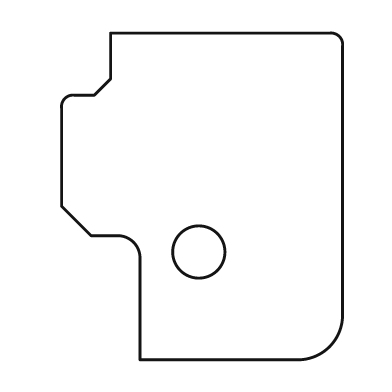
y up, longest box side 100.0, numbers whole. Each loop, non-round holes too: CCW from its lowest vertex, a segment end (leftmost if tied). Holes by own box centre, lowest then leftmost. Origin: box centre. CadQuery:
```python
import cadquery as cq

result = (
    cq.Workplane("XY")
    .moveTo(-19.0, -50.0)
    .lineTo(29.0, -50.0)
    .threePointArc((39.0, -46.0), (43.0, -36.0))
    .lineTo(43.0, 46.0)
    .threePointArc((42.0, 49.0), (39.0, 50.0))
    .lineTo(-28.0, 50.0)
    .lineTo(-28.0, 36.0)
    .lineTo(-33.0, 31.0)
    .lineTo(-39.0, 31.0)
    .threePointArc((-42.0, 30.0), (-43.0, 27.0))
    .lineTo(-43.0, -3.0)
    .lineTo(-34.0, -12.0)
    .lineTo(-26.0, -12.0)
    .threePointArc((-21.0, -14.0), (-19.0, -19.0))
    .close()
    .moveTo(-1.0, -17.0)
    .circle(8.0)
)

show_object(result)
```